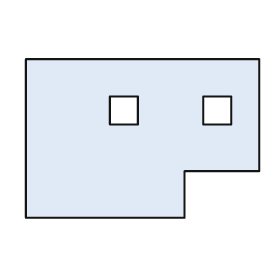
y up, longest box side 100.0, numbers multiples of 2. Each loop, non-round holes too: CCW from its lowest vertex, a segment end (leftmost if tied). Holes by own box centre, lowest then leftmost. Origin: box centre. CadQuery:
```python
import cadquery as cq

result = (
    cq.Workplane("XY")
    .moveTo(-50.0, -34.0)
    .lineTo(18.0, -34.0)
    .lineTo(18.0, -14.0)
    .lineTo(50.0, -14.0)
    .lineTo(50.0, 34.0)
    .lineTo(-50.0, 34.0)
    .close()
    .moveTo(-14.0, 6.0)
    .lineTo(-2.0, 6.0)
    .lineTo(-2.0, 18.0)
    .lineTo(-14.0, 18.0)
    .close()
    .moveTo(26.0, 6.0)
    .lineTo(38.0, 6.0)
    .lineTo(38.0, 18.0)
    .lineTo(26.0, 18.0)
    .close()
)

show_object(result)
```